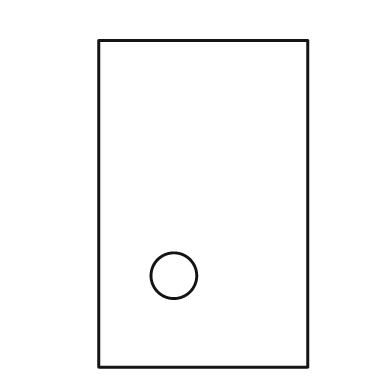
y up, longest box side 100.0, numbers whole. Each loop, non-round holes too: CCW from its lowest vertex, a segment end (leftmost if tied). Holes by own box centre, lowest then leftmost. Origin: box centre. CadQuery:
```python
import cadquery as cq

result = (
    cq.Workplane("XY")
    .moveTo(-32.0, -50.0)
    .lineTo(32.0, -50.0)
    .lineTo(32.0, 50.0)
    .lineTo(-32.0, 50.0)
    .close()
    .moveTo(-9.0, -22.0)
    .circle(7.0)
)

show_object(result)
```